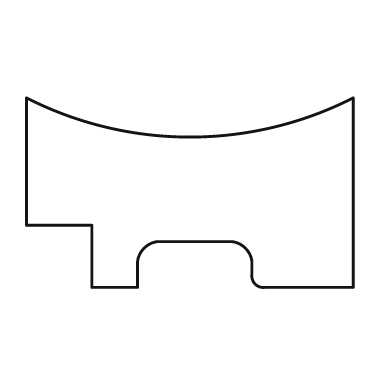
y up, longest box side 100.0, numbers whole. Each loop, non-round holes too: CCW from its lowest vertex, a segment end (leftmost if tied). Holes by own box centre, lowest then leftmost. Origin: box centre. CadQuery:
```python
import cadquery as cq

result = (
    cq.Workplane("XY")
    .moveTo(-30.0, -29.0)
    .lineTo(-16.0, -29.0)
    .lineTo(-16.0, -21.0)
    .threePointArc((-14.0, -17.0), (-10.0, -15.0))
    .lineTo(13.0, -15.0)
    .threePointArc((17.0, -17.0), (19.0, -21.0))
    .lineTo(19.0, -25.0)
    .threePointArc((20.0, -28.0), (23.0, -29.0))
    .lineTo(50.0, -29.0)
    .lineTo(50.0, 29.0)
    .threePointArc((0.0, 17.0), (-50.0, 29.0))
    .lineTo(-50.0, -10.0)
    .lineTo(-30.0, -10.0)
    .close()
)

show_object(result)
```